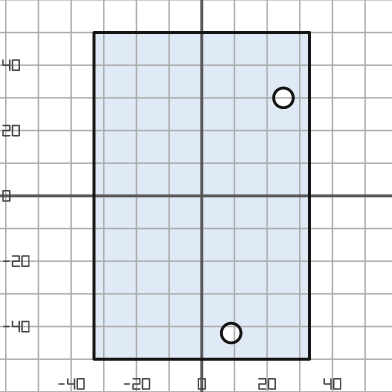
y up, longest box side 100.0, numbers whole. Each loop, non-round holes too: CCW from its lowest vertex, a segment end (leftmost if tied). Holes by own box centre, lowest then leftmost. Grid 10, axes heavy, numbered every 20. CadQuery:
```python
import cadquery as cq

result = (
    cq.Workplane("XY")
    .moveTo(-33.0, -50.0)
    .lineTo(33.0, -50.0)
    .lineTo(33.0, 50.0)
    .lineTo(-33.0, 50.0)
    .close()
    .moveTo(9.0, -42.0)
    .circle(3.0)
    .moveTo(25.0, 30.0)
    .circle(3.0)
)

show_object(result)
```